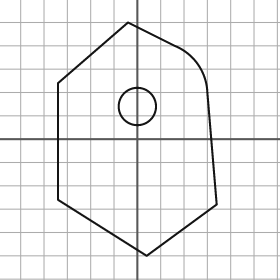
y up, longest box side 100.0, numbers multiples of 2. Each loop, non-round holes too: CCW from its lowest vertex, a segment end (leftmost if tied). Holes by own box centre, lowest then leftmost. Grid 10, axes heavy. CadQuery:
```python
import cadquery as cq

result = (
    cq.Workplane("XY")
    .moveTo(4.0, -50.0)
    .lineTo(34.0, -28.0)
    .lineTo(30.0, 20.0)
    .threePointArc((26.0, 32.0), (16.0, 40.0))
    .lineTo(-4.0, 50.0)
    .lineTo(-34.0, 24.0)
    .lineTo(-34.0, -26.0)
    .close()
    .moveTo(0.0, 14.0)
    .circle(8.0)
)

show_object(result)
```